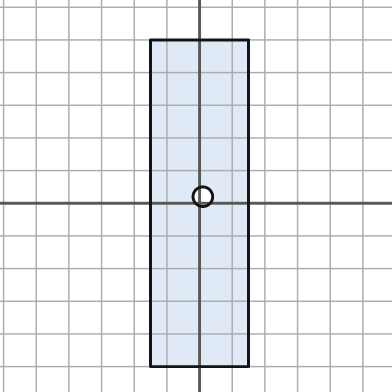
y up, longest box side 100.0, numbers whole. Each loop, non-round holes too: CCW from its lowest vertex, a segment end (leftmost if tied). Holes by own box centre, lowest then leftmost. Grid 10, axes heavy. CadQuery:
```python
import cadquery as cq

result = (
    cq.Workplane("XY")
    .moveTo(-15.0, -50.0)
    .lineTo(15.0, -50.0)
    .lineTo(15.0, 50.0)
    .lineTo(-15.0, 50.0)
    .close()
    .moveTo(1.0, 2.0)
    .circle(3.0)
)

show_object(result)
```